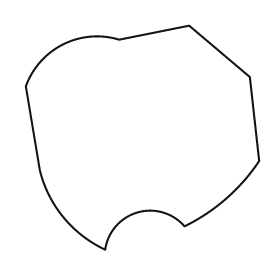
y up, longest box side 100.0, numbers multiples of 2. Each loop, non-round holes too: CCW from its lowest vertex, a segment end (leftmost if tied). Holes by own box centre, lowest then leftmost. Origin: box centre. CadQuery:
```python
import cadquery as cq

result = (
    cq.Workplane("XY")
    .moveTo(-16.0, -48.0)
    .threePointArc((-2.0, -32.0), (18.0, -38.0))
    .threePointArc((36.0, -26.0), (50.0, -10.0))
    .lineTo(46.0, 26.0)
    .lineTo(20.0, 48.0)
    .lineTo(-10.0, 42.0)
    .threePointArc((-34.0, 40.0), (-50.0, 22.0))
    .lineTo(-44.0, -14.0)
    .threePointArc((-34.0, -34.0), (-16.0, -48.0))
    .close()
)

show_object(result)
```